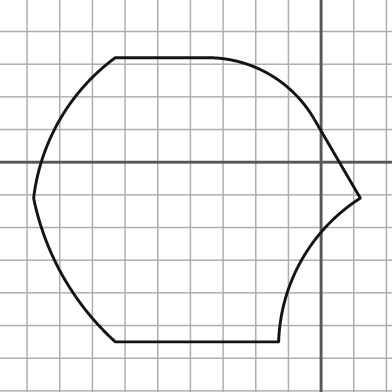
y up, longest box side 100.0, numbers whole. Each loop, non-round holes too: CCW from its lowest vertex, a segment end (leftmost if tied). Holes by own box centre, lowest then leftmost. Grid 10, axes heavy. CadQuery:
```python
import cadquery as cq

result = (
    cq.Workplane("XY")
    .moveTo(-63.0, -55.0)
    .lineTo(-13.0, -55.0)
    .threePointArc((-6.0, -30.0), (12.0, -11.0))
    .lineTo(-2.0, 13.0)
    .threePointArc((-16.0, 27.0), (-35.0, 32.0))
    .lineTo(-63.0, 32.0)
    .threePointArc((-80.0, 13.0), (-88.0, -11.0))
    .threePointArc((-79.0, -35.0), (-63.0, -55.0))
    .close()
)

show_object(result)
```